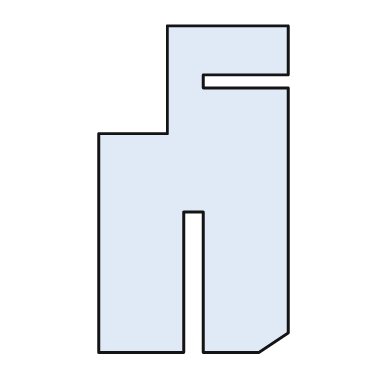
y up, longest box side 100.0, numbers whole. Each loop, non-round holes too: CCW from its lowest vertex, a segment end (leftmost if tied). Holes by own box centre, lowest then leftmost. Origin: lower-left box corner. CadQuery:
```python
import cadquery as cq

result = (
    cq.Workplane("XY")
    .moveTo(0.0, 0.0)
    .lineTo(26.0, 0.0)
    .lineTo(26.0, 43.0)
    .lineTo(32.0, 43.0)
    .lineTo(32.0, 0.0)
    .lineTo(49.0, 0.0)
    .lineTo(58.0, 6.0)
    .lineTo(58.0, 81.0)
    .lineTo(32.0, 81.0)
    .lineTo(32.0, 85.0)
    .lineTo(58.0, 85.0)
    .lineTo(58.0, 100.0)
    .lineTo(21.0, 100.0)
    .lineTo(21.0, 67.0)
    .lineTo(0.0, 67.0)
    .close()
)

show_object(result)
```